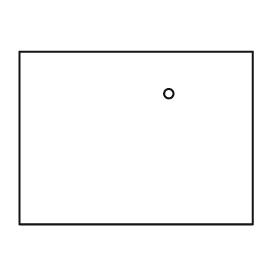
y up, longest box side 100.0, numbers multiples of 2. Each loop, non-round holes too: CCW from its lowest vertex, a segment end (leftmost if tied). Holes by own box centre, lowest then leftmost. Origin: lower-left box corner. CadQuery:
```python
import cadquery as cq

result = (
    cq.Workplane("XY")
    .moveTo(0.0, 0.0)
    .lineTo(100.0, 0.0)
    .lineTo(100.0, 74.0)
    .lineTo(0.0, 74.0)
    .close()
    .moveTo(64.0, 56.0)
    .circle(2.0)
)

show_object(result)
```